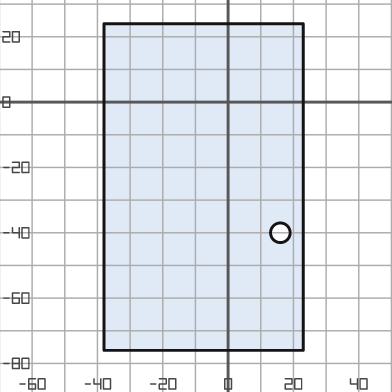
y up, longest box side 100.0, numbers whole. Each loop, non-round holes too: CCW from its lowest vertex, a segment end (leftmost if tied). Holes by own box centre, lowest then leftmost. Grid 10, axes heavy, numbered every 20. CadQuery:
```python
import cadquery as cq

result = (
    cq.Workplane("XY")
    .moveTo(-38.0, -76.0)
    .lineTo(23.0, -76.0)
    .lineTo(23.0, 24.0)
    .lineTo(-38.0, 24.0)
    .close()
    .moveTo(16.0, -40.0)
    .circle(3.0)
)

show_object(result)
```